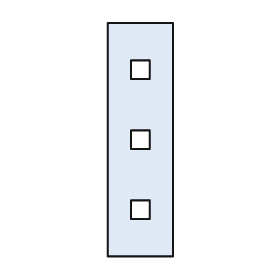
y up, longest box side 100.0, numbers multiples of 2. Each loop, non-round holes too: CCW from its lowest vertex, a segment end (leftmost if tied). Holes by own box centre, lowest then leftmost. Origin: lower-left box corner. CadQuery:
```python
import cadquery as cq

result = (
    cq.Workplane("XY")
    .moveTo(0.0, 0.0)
    .lineTo(28.0, 0.0)
    .lineTo(28.0, 100.0)
    .lineTo(0.0, 100.0)
    .close()
    .moveTo(10.0, 16.0)
    .lineTo(18.0, 16.0)
    .lineTo(18.0, 24.0)
    .lineTo(10.0, 24.0)
    .close()
    .moveTo(10.0, 46.0)
    .lineTo(18.0, 46.0)
    .lineTo(18.0, 54.0)
    .lineTo(10.0, 54.0)
    .close()
    .moveTo(10.0, 76.0)
    .lineTo(18.0, 76.0)
    .lineTo(18.0, 84.0)
    .lineTo(10.0, 84.0)
    .close()
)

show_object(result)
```